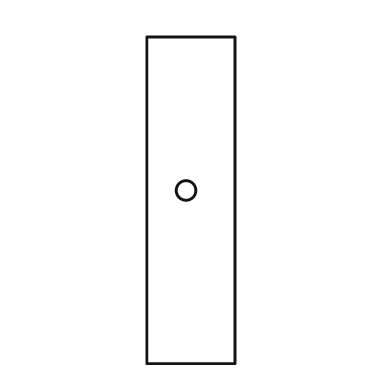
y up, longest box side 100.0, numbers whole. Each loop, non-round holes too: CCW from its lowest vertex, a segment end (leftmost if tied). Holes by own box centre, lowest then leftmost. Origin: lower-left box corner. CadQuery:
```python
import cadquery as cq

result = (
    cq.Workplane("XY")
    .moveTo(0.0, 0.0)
    .lineTo(27.0, 0.0)
    .lineTo(27.0, 100.0)
    .lineTo(0.0, 100.0)
    .close()
    .moveTo(12.0, 53.0)
    .circle(3.0)
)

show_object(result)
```